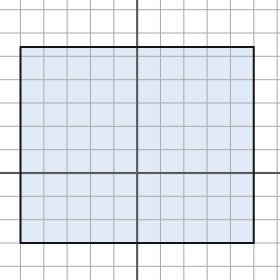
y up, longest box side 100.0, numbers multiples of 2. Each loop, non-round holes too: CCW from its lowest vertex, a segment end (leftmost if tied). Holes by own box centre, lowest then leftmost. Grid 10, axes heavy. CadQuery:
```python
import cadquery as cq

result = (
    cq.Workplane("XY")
    .moveTo(-50.0, -30.0)
    .lineTo(50.0, -30.0)
    .lineTo(50.0, 54.0)
    .lineTo(-50.0, 54.0)
    .close()
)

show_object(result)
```